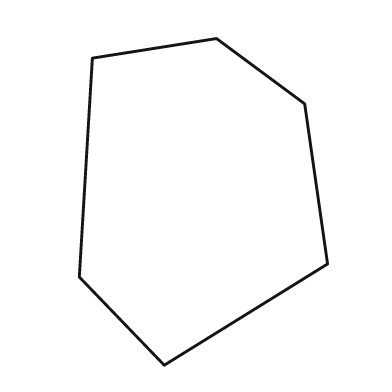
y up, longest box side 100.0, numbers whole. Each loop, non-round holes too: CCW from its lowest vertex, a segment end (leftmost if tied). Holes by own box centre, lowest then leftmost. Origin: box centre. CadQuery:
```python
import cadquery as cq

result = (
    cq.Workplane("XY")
    .moveTo(-12.0, -50.0)
    .lineTo(38.0, -19.0)
    .lineTo(31.0, 30.0)
    .lineTo(4.0, 50.0)
    .lineTo(-34.0, 44.0)
    .lineTo(-38.0, -23.0)
    .close()
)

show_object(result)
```